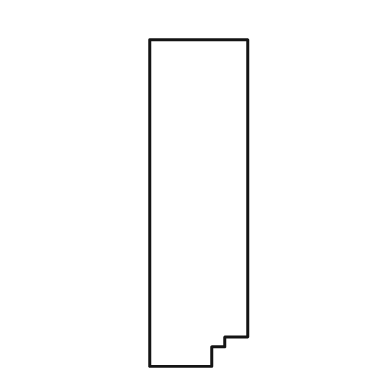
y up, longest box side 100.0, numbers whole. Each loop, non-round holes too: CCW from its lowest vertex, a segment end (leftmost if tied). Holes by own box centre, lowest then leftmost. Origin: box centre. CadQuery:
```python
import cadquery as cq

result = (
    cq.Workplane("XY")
    .moveTo(-15.0, -50.0)
    .lineTo(4.0, -50.0)
    .lineTo(4.0, -44.0)
    .lineTo(8.0, -44.0)
    .lineTo(8.0, -41.0)
    .lineTo(15.0, -41.0)
    .lineTo(15.0, 50.0)
    .lineTo(-15.0, 50.0)
    .close()
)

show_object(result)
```